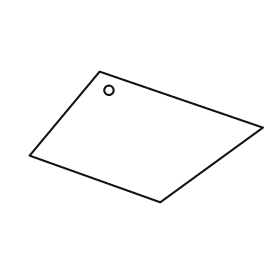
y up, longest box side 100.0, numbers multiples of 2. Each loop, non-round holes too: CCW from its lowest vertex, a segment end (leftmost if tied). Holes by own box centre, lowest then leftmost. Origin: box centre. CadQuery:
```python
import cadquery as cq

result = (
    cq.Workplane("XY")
    .moveTo(6.0, -28.0)
    .lineTo(50.0, 4.0)
    .lineTo(-20.0, 28.0)
    .lineTo(-50.0, -8.0)
    .close()
    .moveTo(-16.0, 20.0)
    .circle(2.0)
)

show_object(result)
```